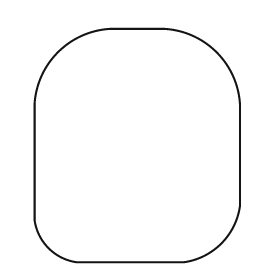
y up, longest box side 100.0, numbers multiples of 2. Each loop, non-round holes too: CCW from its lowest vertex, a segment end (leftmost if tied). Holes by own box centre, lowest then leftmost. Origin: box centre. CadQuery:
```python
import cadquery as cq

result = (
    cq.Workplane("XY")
    .moveTo(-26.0, -50.0)
    .lineTo(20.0, -50.0)
    .threePointArc((36.0, -42.0), (44.0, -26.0))
    .lineTo(44.0, 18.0)
    .threePointArc((34.0, 40.0), (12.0, 50.0))
    .lineTo(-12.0, 50.0)
    .threePointArc((-34.0, 40.0), (-44.0, 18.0))
    .lineTo(-44.0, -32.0)
    .threePointArc((-38.0, -44.0), (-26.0, -50.0))
    .close()
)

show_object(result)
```